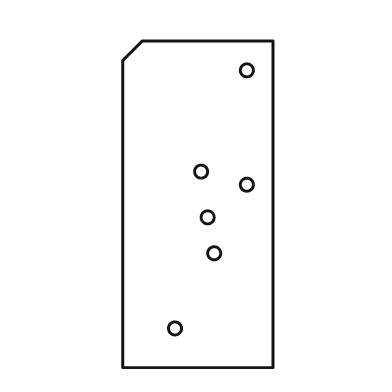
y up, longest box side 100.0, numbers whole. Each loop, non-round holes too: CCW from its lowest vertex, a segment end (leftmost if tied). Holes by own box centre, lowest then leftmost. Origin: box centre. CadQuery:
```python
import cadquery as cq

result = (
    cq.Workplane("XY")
    .moveTo(-23.0, -50.0)
    .lineTo(23.0, -50.0)
    .lineTo(23.0, 50.0)
    .lineTo(-17.0, 50.0)
    .lineTo(-23.0, 44.0)
    .close()
    .moveTo(-7.0, -38.0)
    .circle(2.0)
    .moveTo(5.0, -15.0)
    .circle(2.0)
    .moveTo(3.0, -4.0)
    .circle(2.0)
    .moveTo(15.0, 6.0)
    .circle(2.0)
    .moveTo(1.0, 10.0)
    .circle(2.0)
    .moveTo(15.0, 41.0)
    .circle(2.0)
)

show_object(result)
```